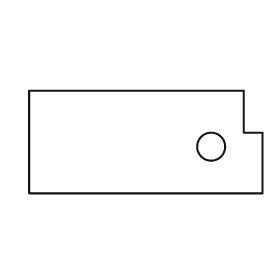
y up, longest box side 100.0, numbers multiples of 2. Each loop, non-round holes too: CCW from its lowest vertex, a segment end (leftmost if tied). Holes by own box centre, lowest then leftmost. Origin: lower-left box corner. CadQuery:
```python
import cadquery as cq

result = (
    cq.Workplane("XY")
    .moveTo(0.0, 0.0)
    .lineTo(100.0, 0.0)
    .lineTo(100.0, 26.0)
    .lineTo(92.0, 26.0)
    .lineTo(92.0, 44.0)
    .lineTo(0.0, 44.0)
    .close()
    .moveTo(78.0, 20.0)
    .circle(6.0)
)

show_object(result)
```